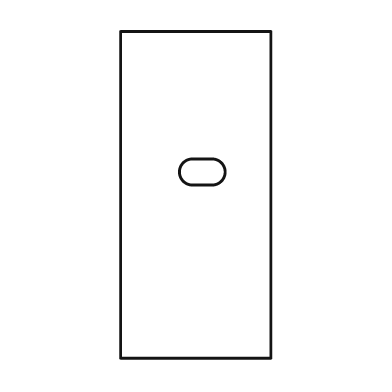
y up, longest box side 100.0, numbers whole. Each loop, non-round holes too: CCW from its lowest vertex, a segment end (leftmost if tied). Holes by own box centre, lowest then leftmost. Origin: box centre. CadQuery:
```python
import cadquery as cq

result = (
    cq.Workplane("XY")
    .moveTo(-23.0, -50.0)
    .lineTo(23.0, -50.0)
    .lineTo(23.0, 50.0)
    .lineTo(-23.0, 50.0)
    .close()
    .moveTo(-1.0, 3.0)
    .lineTo(5.0, 3.0)
    .threePointArc((9.0, 7.0), (5.0, 11.0))
    .lineTo(-1.0, 11.0)
    .threePointArc((-5.0, 7.0), (-1.0, 3.0))
    .close()
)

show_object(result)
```